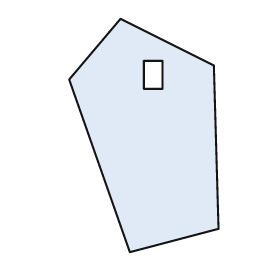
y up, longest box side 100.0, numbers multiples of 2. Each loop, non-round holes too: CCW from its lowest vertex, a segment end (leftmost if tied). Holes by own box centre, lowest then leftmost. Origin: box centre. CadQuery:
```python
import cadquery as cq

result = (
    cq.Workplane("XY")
    .moveTo(-6.0, -50.0)
    .lineTo(32.0, -40.0)
    .lineTo(30.0, 30.0)
    .lineTo(-10.0, 50.0)
    .lineTo(-32.0, 24.0)
    .close()
    .moveTo(0.0, 20.0)
    .lineTo(8.0, 20.0)
    .lineTo(8.0, 32.0)
    .lineTo(0.0, 32.0)
    .close()
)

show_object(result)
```